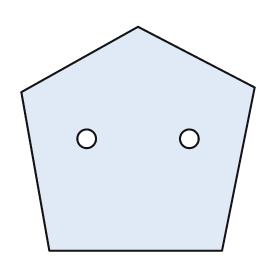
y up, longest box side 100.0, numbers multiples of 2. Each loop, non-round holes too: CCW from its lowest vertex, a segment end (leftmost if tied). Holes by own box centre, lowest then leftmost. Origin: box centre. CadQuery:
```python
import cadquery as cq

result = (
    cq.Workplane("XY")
    .moveTo(-38.0, -48.0)
    .lineTo(36.0, -48.0)
    .lineTo(50.0, 22.0)
    .lineTo(0.0, 48.0)
    .lineTo(-50.0, 20.0)
    .close()
    .moveTo(-22.0, 0.0)
    .circle(4.0)
    .moveTo(22.0, 0.0)
    .circle(4.0)
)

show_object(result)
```